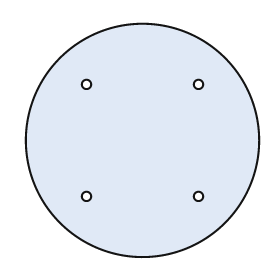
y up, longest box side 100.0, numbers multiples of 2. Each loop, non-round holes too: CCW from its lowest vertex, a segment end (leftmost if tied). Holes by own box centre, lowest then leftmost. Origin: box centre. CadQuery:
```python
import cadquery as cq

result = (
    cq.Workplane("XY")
    .moveTo(0.0, 0.0)
    .circle(50.0)
    .moveTo(-24.0, -24.0)
    .circle(2.0)
    .moveTo(24.0, -24.0)
    .circle(2.0)
    .moveTo(-24.0, 24.0)
    .circle(2.0)
    .moveTo(24.0, 24.0)
    .circle(2.0)
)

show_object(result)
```